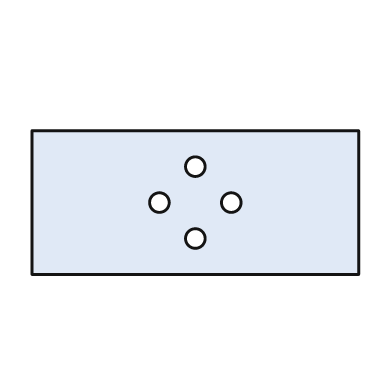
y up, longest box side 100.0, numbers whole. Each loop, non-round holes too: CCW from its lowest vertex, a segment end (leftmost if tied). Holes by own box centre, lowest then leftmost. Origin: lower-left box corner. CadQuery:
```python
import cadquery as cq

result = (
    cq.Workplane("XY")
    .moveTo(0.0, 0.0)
    .lineTo(100.0, 0.0)
    .lineTo(100.0, 44.0)
    .lineTo(0.0, 44.0)
    .close()
    .moveTo(50.0, 11.0)
    .circle(3.0)
    .moveTo(39.0, 22.0)
    .circle(3.0)
    .moveTo(61.0, 22.0)
    .circle(3.0)
    .moveTo(50.0, 33.0)
    .circle(3.0)
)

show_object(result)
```